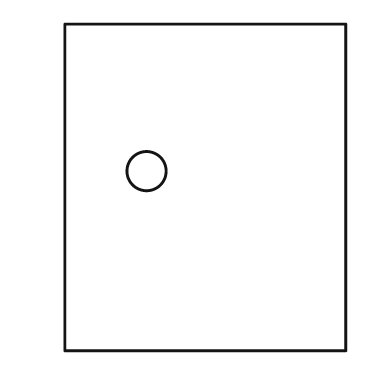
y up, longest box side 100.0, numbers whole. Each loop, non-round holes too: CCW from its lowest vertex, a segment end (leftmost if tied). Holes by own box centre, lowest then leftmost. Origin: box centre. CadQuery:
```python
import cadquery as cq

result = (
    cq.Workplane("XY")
    .moveTo(-43.0, -50.0)
    .lineTo(43.0, -50.0)
    .lineTo(43.0, 50.0)
    .lineTo(-43.0, 50.0)
    .close()
    .moveTo(-18.0, 5.0)
    .circle(6.0)
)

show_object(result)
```